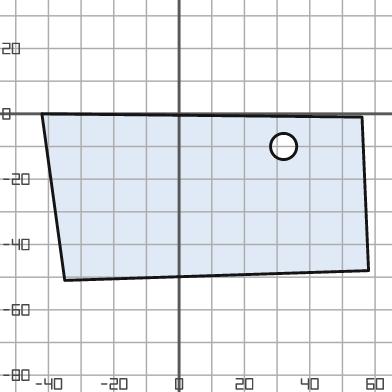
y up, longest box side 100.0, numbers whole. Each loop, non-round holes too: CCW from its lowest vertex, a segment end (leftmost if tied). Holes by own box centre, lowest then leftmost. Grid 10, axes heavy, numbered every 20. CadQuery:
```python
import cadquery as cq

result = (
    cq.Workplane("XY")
    .moveTo(-35.0, -51.0)
    .lineTo(58.0, -48.0)
    .lineTo(56.0, -1.0)
    .lineTo(-42.0, 0.0)
    .close()
    .moveTo(32.0, -10.0)
    .circle(4.0)
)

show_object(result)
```